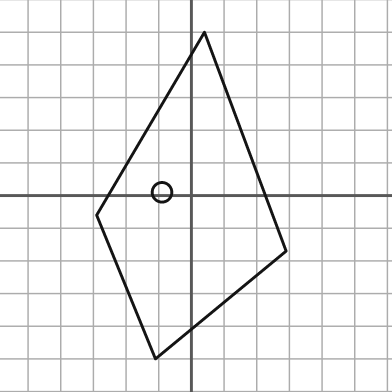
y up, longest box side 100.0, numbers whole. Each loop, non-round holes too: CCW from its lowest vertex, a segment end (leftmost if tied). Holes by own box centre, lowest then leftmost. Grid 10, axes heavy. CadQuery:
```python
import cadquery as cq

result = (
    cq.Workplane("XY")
    .moveTo(-11.0, -50.0)
    .lineTo(29.0, -17.0)
    .lineTo(4.0, 50.0)
    .lineTo(-29.0, -6.0)
    .close()
    .moveTo(-9.0, 1.0)
    .circle(3.0)
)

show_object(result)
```